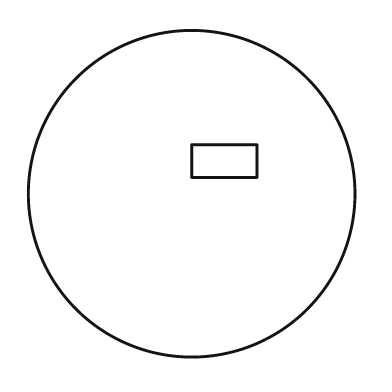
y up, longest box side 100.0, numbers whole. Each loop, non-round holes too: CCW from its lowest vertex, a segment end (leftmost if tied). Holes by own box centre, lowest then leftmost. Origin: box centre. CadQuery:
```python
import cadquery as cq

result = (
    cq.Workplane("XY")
    .moveTo(0.0, 0.0)
    .circle(50.0)
    .moveTo(0.0, 5.0)
    .lineTo(20.0, 5.0)
    .lineTo(20.0, 15.0)
    .lineTo(0.0, 15.0)
    .close()
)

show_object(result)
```